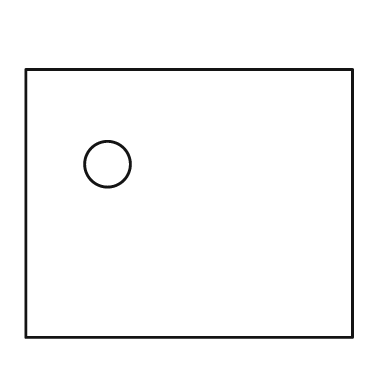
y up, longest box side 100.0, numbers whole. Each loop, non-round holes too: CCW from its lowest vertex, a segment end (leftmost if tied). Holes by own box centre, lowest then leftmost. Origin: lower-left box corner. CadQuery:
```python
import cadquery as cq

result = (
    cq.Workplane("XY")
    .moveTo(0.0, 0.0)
    .lineTo(100.0, 0.0)
    .lineTo(100.0, 82.0)
    .lineTo(0.0, 82.0)
    .close()
    .moveTo(25.0, 53.0)
    .circle(7.0)
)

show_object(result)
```